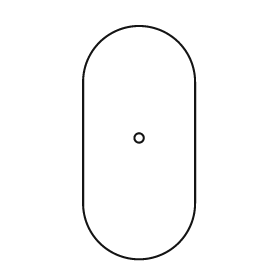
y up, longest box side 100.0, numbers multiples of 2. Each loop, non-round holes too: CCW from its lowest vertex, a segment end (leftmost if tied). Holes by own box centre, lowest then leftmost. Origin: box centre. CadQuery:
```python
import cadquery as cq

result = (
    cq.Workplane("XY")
    .moveTo(-24.0, -26.0)
    .threePointArc((0.0, -50.0), (24.0, -26.0))
    .lineTo(24.0, 26.0)
    .threePointArc((0.0, 50.0), (-24.0, 26.0))
    .close()
    .moveTo(0.0, 2.0)
    .circle(2.0)
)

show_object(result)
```